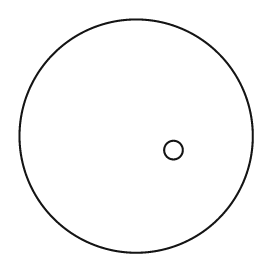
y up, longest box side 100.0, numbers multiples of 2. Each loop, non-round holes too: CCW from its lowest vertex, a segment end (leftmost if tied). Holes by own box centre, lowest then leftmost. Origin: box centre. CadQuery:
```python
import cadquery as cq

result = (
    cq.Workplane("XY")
    .moveTo(0.0, 0.0)
    .circle(50.0)
    .moveTo(16.0, -6.0)
    .circle(4.0)
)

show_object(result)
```